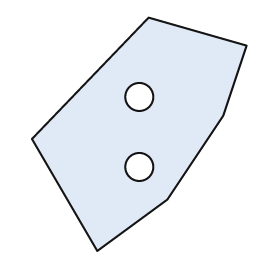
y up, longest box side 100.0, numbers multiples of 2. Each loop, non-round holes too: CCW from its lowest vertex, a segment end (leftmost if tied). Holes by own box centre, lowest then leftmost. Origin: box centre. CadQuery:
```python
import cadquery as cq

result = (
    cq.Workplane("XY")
    .moveTo(-18.0, -50.0)
    .lineTo(12.0, -28.0)
    .lineTo(36.0, 8.0)
    .lineTo(46.0, 38.0)
    .lineTo(4.0, 50.0)
    .lineTo(-46.0, -2.0)
    .close()
    .moveTo(0.0, -14.0)
    .circle(6.0)
    .moveTo(0.0, 16.0)
    .circle(6.0)
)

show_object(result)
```